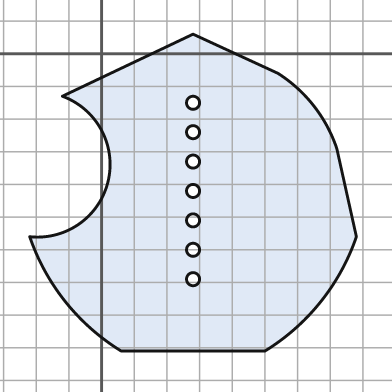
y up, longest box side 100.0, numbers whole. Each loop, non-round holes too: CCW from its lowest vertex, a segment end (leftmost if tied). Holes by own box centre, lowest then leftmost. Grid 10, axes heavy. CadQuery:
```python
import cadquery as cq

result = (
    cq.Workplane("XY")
    .moveTo(6.0, -91.0)
    .lineTo(50.0, -91.0)
    .threePointArc((67.0, -76.0), (78.0, -56.0))
    .lineTo(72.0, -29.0)
    .threePointArc((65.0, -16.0), (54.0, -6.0))
    .lineTo(28.0, 6.0)
    .lineTo(-12.0, -13.0)
    .threePointArc((2.0, -39.0), (-22.0, -56.0))
    .threePointArc((-11.0, -76.0), (6.0, -91.0))
    .close()
    .moveTo(28.0, -69.0)
    .circle(2.0)
    .moveTo(28.0, -60.0)
    .circle(2.0)
    .moveTo(28.0, -51.0)
    .circle(2.0)
    .moveTo(28.0, -42.0)
    .circle(2.0)
    .moveTo(28.0, -33.0)
    .circle(2.0)
    .moveTo(28.0, -24.0)
    .circle(2.0)
    .moveTo(28.0, -15.0)
    .circle(2.0)
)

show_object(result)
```